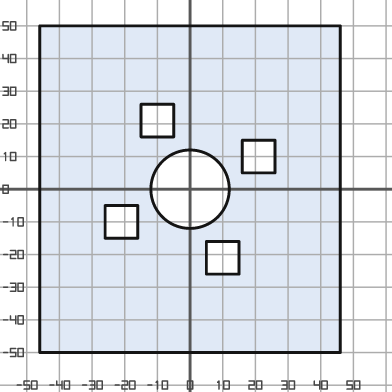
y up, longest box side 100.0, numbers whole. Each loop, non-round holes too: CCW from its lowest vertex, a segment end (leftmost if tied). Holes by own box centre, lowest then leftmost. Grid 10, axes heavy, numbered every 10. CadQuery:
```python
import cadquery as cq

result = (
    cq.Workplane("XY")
    .moveTo(-46.0, -50.0)
    .lineTo(46.0, -50.0)
    .lineTo(46.0, 50.0)
    .lineTo(-46.0, 50.0)
    .close()
    .moveTo(5.0, -26.0)
    .lineTo(15.0, -26.0)
    .lineTo(15.0, -16.0)
    .lineTo(5.0, -16.0)
    .close()
    .moveTo(-26.0, -15.0)
    .lineTo(-16.0, -15.0)
    .lineTo(-16.0, -5.0)
    .lineTo(-26.0, -5.0)
    .close()
    .moveTo(0.0, 0.0)
    .circle(12.0)
    .moveTo(16.0, 5.0)
    .lineTo(26.0, 5.0)
    .lineTo(26.0, 15.0)
    .lineTo(16.0, 15.0)
    .close()
    .moveTo(-15.0, 16.0)
    .lineTo(-5.0, 16.0)
    .lineTo(-5.0, 26.0)
    .lineTo(-15.0, 26.0)
    .close()
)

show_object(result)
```